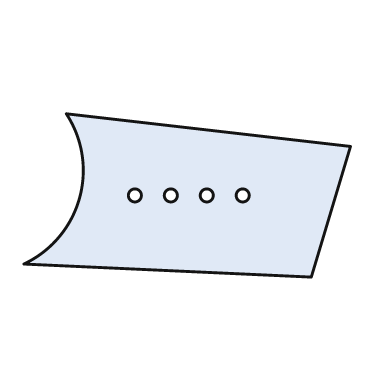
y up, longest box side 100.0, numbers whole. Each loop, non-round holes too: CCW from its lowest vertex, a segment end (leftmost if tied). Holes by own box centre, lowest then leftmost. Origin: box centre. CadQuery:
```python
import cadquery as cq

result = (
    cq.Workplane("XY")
    .moveTo(38.0, -25.0)
    .lineTo(50.0, 15.0)
    .lineTo(-37.0, 25.0)
    .threePointArc((-33.0, -1.0), (-50.0, -21.0))
    .close()
    .moveTo(-16.0, 0.0)
    .circle(2.0)
    .moveTo(-5.0, 0.0)
    .circle(2.0)
    .moveTo(6.0, 0.0)
    .circle(2.0)
    .moveTo(17.0, 0.0)
    .circle(2.0)
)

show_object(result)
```